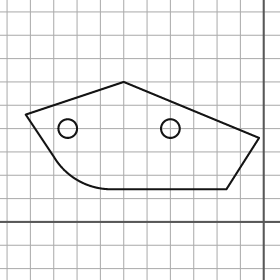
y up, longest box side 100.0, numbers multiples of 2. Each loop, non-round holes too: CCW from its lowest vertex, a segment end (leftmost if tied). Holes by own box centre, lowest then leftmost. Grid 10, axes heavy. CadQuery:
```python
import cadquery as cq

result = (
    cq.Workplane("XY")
    .moveTo(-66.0, 14.0)
    .lineTo(-16.0, 14.0)
    .lineTo(-2.0, 36.0)
    .lineTo(-60.0, 60.0)
    .lineTo(-102.0, 46.0)
    .lineTo(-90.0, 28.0)
    .threePointArc((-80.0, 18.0), (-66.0, 14.0))
    .close()
    .moveTo(-84.0, 40.0)
    .circle(4.0)
    .moveTo(-40.0, 40.0)
    .circle(4.0)
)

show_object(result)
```